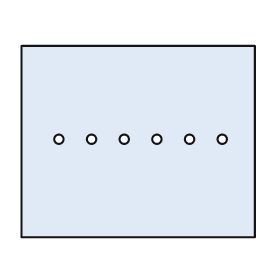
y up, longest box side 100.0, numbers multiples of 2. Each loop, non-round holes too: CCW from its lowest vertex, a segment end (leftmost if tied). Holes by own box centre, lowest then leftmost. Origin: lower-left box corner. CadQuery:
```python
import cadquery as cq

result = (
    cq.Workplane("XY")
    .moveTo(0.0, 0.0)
    .lineTo(100.0, 0.0)
    .lineTo(100.0, 82.0)
    .lineTo(0.0, 82.0)
    .close()
    .moveTo(16.0, 42.0)
    .circle(2.0)
    .moveTo(30.0, 42.0)
    .circle(2.0)
    .moveTo(44.0, 42.0)
    .circle(2.0)
    .moveTo(58.0, 42.0)
    .circle(2.0)
    .moveTo(72.0, 42.0)
    .circle(2.0)
    .moveTo(86.0, 42.0)
    .circle(2.0)
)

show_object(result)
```